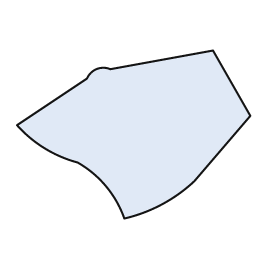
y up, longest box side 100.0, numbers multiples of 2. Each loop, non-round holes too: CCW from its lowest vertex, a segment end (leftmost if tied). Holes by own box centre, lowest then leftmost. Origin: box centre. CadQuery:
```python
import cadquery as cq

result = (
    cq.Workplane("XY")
    .moveTo(-4.0, -36.0)
    .threePointArc((12.0, -30.0), (26.0, -20.0))
    .lineTo(50.0, 8.0)
    .lineTo(34.0, 36.0)
    .lineTo(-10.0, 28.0)
    .threePointArc((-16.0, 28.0), (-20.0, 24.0))
    .lineTo(-50.0, 4.0)
    .threePointArc((-38.0, -6.0), (-24.0, -12.0))
    .threePointArc((-12.0, -22.0), (-4.0, -36.0))
    .close()
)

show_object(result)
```